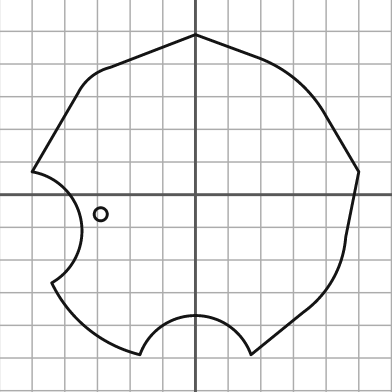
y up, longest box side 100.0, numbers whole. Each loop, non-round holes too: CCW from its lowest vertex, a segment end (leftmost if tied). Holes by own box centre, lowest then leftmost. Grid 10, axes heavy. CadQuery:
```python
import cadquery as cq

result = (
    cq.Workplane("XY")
    .moveTo(-17.0, -49.0)
    .threePointArc((0.0, -37.0), (17.0, -49.0))
    .lineTo(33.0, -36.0)
    .threePointArc((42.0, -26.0), (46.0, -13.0))
    .lineTo(50.0, 7.0)
    .lineTo(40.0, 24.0)
    .threePointArc((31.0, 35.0), (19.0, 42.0))
    .lineTo(0.0, 49.0)
    .lineTo(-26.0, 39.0)
    .threePointArc((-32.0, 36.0), (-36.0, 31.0))
    .lineTo(-50.0, 7.0)
    .threePointArc((-35.0, -8.0), (-44.0, -27.0))
    .threePointArc((-33.0, -41.0), (-17.0, -49.0))
    .close()
    .moveTo(-29.0, -6.0)
    .circle(2.0)
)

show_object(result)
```